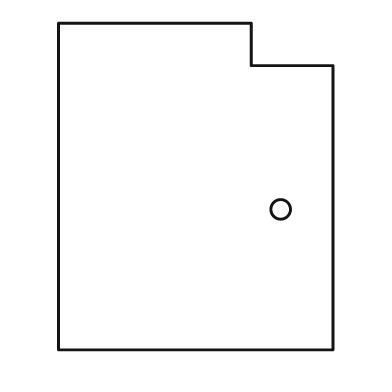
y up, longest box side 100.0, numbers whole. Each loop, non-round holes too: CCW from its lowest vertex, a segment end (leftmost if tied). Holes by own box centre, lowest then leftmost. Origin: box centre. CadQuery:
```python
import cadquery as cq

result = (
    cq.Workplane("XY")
    .moveTo(-42.0, -50.0)
    .lineTo(42.0, -50.0)
    .lineTo(42.0, 37.0)
    .lineTo(17.0, 37.0)
    .lineTo(17.0, 50.0)
    .lineTo(-42.0, 50.0)
    .close()
    .moveTo(26.0, -7.0)
    .circle(3.0)
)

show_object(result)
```